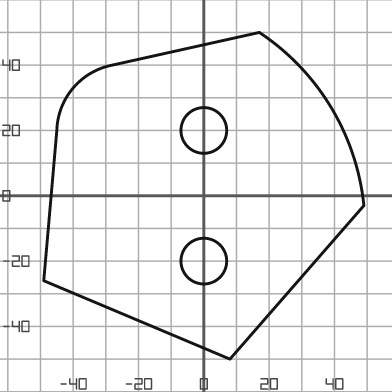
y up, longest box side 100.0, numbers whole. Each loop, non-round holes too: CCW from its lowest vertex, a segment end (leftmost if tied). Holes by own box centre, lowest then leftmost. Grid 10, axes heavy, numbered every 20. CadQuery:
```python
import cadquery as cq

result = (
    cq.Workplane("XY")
    .moveTo(8.0, -50.0)
    .lineTo(49.0, -3.0)
    .threePointArc((39.0, 27.0), (17.0, 50.0))
    .lineTo(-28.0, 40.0)
    .threePointArc((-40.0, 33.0), (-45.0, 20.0))
    .lineTo(-49.0, -26.0)
    .close()
    .moveTo(0.0, -20.0)
    .circle(7.0)
    .moveTo(0.0, 20.0)
    .circle(7.0)
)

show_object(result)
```